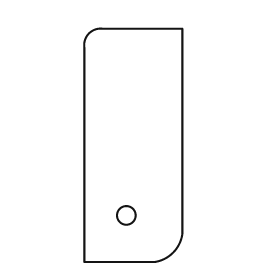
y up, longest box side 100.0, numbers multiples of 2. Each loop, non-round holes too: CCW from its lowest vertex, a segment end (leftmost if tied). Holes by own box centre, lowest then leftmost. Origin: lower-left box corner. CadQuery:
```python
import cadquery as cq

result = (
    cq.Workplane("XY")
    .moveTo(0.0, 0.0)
    .lineTo(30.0, 0.0)
    .threePointArc((38.0, 4.0), (42.0, 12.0))
    .lineTo(42.0, 100.0)
    .lineTo(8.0, 100.0)
    .threePointArc((2.0, 98.0), (0.0, 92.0))
    .close()
    .moveTo(18.0, 20.0)
    .circle(4.0)
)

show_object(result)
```